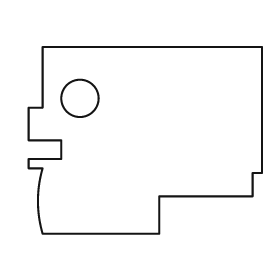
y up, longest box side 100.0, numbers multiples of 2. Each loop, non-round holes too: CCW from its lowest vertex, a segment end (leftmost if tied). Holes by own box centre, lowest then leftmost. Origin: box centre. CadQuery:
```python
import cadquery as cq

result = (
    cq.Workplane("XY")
    .moveTo(-44.0, -40.0)
    .lineTo(6.0, -40.0)
    .lineTo(6.0, -24.0)
    .lineTo(46.0, -24.0)
    .lineTo(46.0, -14.0)
    .lineTo(50.0, -14.0)
    .lineTo(50.0, 40.0)
    .lineTo(-44.0, 40.0)
    .lineTo(-44.0, 14.0)
    .lineTo(-50.0, 14.0)
    .lineTo(-50.0, 0.0)
    .lineTo(-36.0, 0.0)
    .lineTo(-36.0, -8.0)
    .lineTo(-50.0, -8.0)
    .lineTo(-50.0, -12.0)
    .lineTo(-44.0, -12.0)
    .threePointArc((-46.0, -26.0), (-44.0, -40.0))
    .close()
    .moveTo(-28.0, 18.0)
    .circle(8.0)
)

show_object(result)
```